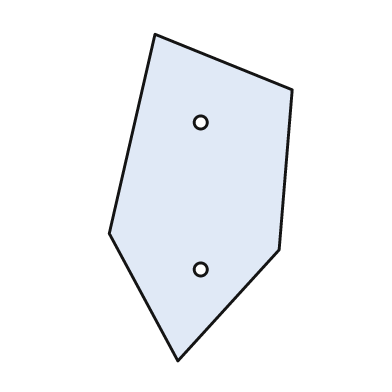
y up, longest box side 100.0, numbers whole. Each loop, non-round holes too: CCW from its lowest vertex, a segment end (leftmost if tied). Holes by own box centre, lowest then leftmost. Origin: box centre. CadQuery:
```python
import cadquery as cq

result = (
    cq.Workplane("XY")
    .moveTo(-7.0, -50.0)
    .lineTo(24.0, -16.0)
    .lineTo(28.0, 33.0)
    .lineTo(-14.0, 50.0)
    .lineTo(-28.0, -11.0)
    .close()
    .moveTo(0.0, -22.0)
    .circle(2.0)
    .moveTo(0.0, 23.0)
    .circle(2.0)
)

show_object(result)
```